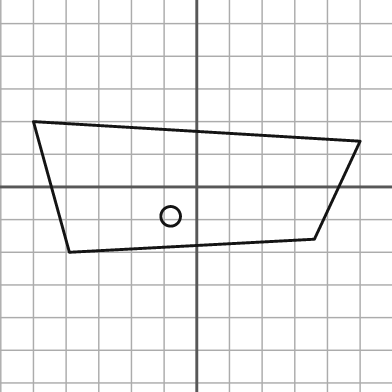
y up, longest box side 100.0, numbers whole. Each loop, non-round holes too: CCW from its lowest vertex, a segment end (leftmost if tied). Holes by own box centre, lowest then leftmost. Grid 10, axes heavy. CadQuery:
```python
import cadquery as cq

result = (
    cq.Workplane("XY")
    .moveTo(-39.0, -20.0)
    .lineTo(36.0, -16.0)
    .lineTo(50.0, 14.0)
    .lineTo(-50.0, 20.0)
    .close()
    .moveTo(-8.0, -9.0)
    .circle(3.0)
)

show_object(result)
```